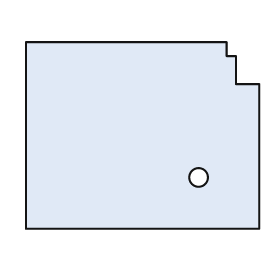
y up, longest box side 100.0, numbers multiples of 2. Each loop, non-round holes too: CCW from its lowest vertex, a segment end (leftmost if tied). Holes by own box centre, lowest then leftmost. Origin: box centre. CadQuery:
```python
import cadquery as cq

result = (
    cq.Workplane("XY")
    .moveTo(-50.0, -40.0)
    .lineTo(50.0, -40.0)
    .lineTo(50.0, 22.0)
    .lineTo(40.0, 22.0)
    .lineTo(40.0, 34.0)
    .lineTo(36.0, 34.0)
    .lineTo(36.0, 40.0)
    .lineTo(-50.0, 40.0)
    .close()
    .moveTo(24.0, -18.0)
    .circle(4.0)
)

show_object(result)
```